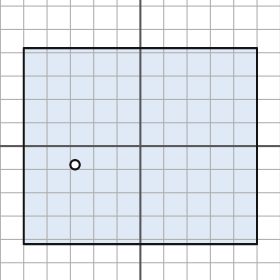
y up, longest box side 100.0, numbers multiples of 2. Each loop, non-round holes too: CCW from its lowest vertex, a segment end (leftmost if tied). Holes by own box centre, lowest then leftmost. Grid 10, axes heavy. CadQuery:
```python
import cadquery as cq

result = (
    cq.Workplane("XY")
    .moveTo(-50.0, -42.0)
    .lineTo(50.0, -42.0)
    .lineTo(50.0, 42.0)
    .lineTo(-50.0, 42.0)
    .close()
    .moveTo(-28.0, -8.0)
    .circle(2.0)
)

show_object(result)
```